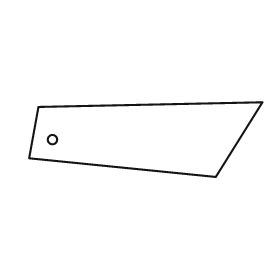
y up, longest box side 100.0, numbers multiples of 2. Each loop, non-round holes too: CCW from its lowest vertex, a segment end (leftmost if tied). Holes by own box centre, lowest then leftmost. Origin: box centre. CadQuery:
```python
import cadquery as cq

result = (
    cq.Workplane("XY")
    .moveTo(30.0, -16.0)
    .lineTo(50.0, 16.0)
    .lineTo(-46.0, 14.0)
    .lineTo(-50.0, -8.0)
    .close()
    .moveTo(-40.0, 0.0)
    .circle(2.0)
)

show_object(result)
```